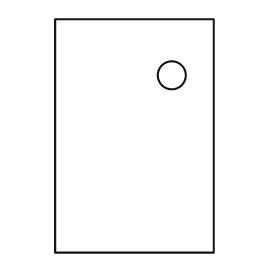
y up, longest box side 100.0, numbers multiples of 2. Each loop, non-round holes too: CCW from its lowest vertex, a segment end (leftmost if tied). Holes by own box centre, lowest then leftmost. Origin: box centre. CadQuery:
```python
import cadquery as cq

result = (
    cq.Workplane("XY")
    .moveTo(-34.0, -50.0)
    .lineTo(34.0, -50.0)
    .lineTo(34.0, 50.0)
    .lineTo(-34.0, 50.0)
    .close()
    .moveTo(16.0, 26.0)
    .circle(6.0)
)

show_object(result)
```